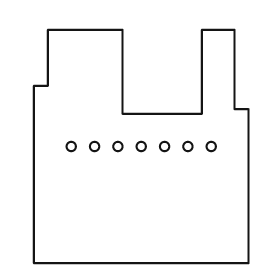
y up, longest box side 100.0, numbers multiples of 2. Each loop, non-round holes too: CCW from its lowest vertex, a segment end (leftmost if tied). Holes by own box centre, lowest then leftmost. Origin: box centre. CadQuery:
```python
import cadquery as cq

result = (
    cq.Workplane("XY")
    .moveTo(-46.0, -50.0)
    .lineTo(46.0, -50.0)
    .lineTo(46.0, 16.0)
    .lineTo(40.0, 16.0)
    .lineTo(40.0, 50.0)
    .lineTo(26.0, 50.0)
    .lineTo(26.0, 14.0)
    .lineTo(-8.0, 14.0)
    .lineTo(-8.0, 50.0)
    .lineTo(-40.0, 50.0)
    .lineTo(-40.0, 26.0)
    .lineTo(-46.0, 26.0)
    .close()
    .moveTo(-30.0, 0.0)
    .circle(2.0)
    .moveTo(-20.0, 0.0)
    .circle(2.0)
    .moveTo(-10.0, 0.0)
    .circle(2.0)
    .moveTo(0.0, 0.0)
    .circle(2.0)
    .moveTo(10.0, 0.0)
    .circle(2.0)
    .moveTo(20.0, 0.0)
    .circle(2.0)
    .moveTo(30.0, 0.0)
    .circle(2.0)
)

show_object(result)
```